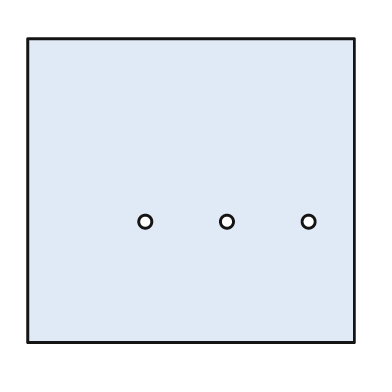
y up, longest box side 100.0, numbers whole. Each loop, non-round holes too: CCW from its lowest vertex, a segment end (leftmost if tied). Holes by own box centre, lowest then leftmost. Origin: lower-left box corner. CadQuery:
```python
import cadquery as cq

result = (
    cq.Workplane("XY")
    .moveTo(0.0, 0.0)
    .lineTo(100.0, 0.0)
    .lineTo(100.0, 93.0)
    .lineTo(0.0, 93.0)
    .close()
    .moveTo(36.0, 37.0)
    .circle(2.0)
    .moveTo(61.0, 37.0)
    .circle(2.0)
    .moveTo(86.0, 37.0)
    .circle(2.0)
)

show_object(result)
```